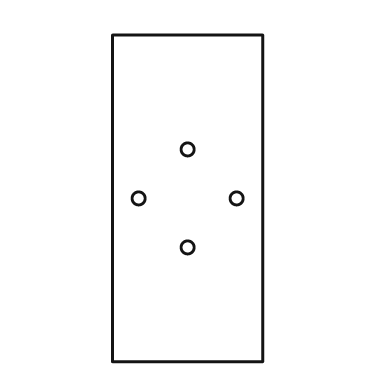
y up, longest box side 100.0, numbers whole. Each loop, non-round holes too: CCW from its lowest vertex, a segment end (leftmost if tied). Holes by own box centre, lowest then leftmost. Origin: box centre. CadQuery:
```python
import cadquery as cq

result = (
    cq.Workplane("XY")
    .moveTo(-23.0, -50.0)
    .lineTo(23.0, -50.0)
    .lineTo(23.0, 50.0)
    .lineTo(-23.0, 50.0)
    .close()
    .moveTo(0.0, -15.0)
    .circle(2.0)
    .moveTo(-15.0, 0.0)
    .circle(2.0)
    .moveTo(15.0, 0.0)
    .circle(2.0)
    .moveTo(0.0, 15.0)
    .circle(2.0)
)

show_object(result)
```